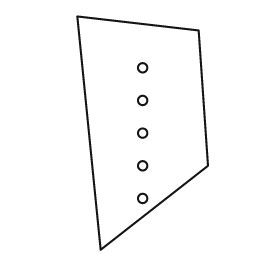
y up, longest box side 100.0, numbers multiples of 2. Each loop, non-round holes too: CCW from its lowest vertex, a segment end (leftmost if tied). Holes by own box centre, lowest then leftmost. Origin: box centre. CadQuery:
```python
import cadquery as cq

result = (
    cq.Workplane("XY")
    .moveTo(-18.0, -50.0)
    .lineTo(28.0, -14.0)
    .lineTo(24.0, 44.0)
    .lineTo(-28.0, 50.0)
    .close()
    .moveTo(0.0, -28.0)
    .circle(2.0)
    .moveTo(0.0, -14.0)
    .circle(2.0)
    .moveTo(0.0, 0.0)
    .circle(2.0)
    .moveTo(0.0, 14.0)
    .circle(2.0)
    .moveTo(0.0, 28.0)
    .circle(2.0)
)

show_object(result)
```